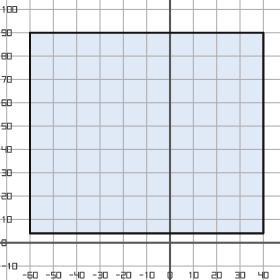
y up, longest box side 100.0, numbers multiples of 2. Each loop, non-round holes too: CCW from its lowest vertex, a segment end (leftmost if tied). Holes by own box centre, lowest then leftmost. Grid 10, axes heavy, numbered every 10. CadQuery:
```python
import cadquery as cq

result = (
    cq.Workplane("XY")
    .moveTo(-60.0, 4.0)
    .lineTo(40.0, 4.0)
    .lineTo(40.0, 90.0)
    .lineTo(-60.0, 90.0)
    .close()
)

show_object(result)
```